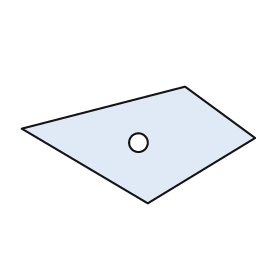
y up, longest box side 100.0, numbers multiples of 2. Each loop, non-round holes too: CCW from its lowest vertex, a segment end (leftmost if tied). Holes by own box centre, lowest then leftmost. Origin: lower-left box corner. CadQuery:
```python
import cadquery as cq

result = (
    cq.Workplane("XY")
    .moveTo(54.0, 0.0)
    .lineTo(100.0, 28.0)
    .lineTo(70.0, 50.0)
    .lineTo(0.0, 32.0)
    .close()
    .moveTo(50.0, 26.0)
    .circle(4.0)
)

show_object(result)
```